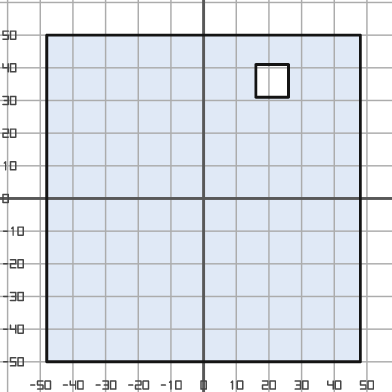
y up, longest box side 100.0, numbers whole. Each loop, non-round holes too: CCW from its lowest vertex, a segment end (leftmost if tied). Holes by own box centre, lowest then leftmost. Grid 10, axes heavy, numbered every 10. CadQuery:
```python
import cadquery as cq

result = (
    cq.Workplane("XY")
    .moveTo(-48.0, -50.0)
    .lineTo(48.0, -50.0)
    .lineTo(48.0, 50.0)
    .lineTo(-48.0, 50.0)
    .close()
    .moveTo(16.0, 31.0)
    .lineTo(26.0, 31.0)
    .lineTo(26.0, 41.0)
    .lineTo(16.0, 41.0)
    .close()
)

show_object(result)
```